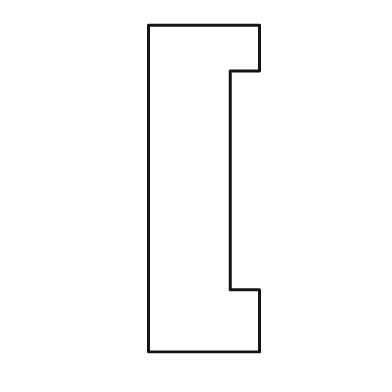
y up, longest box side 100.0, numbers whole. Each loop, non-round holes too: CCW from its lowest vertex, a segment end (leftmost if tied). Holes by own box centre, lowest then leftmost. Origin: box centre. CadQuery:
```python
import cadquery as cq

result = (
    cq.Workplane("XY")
    .moveTo(-17.0, -50.0)
    .lineTo(17.0, -50.0)
    .lineTo(17.0, -31.0)
    .lineTo(8.0, -31.0)
    .lineTo(8.0, 36.0)
    .lineTo(17.0, 36.0)
    .lineTo(17.0, 50.0)
    .lineTo(-17.0, 50.0)
    .close()
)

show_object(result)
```